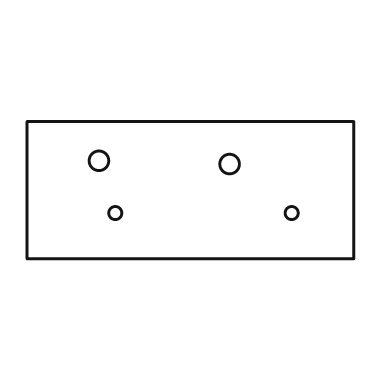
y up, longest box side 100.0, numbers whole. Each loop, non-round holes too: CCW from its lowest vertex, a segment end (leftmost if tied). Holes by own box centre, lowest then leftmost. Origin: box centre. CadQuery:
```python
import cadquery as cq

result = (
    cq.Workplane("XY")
    .moveTo(-50.0, -21.0)
    .lineTo(50.0, -21.0)
    .lineTo(50.0, 21.0)
    .lineTo(-50.0, 21.0)
    .close()
    .moveTo(-23.0, -7.0)
    .circle(2.0)
    .moveTo(31.0, -7.0)
    .circle(2.0)
    .moveTo(12.0, 8.0)
    .circle(3.0)
    .moveTo(-28.0, 9.0)
    .circle(3.0)
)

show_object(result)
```